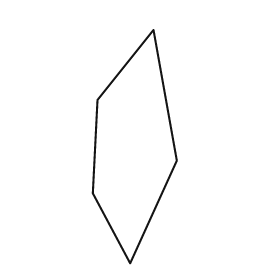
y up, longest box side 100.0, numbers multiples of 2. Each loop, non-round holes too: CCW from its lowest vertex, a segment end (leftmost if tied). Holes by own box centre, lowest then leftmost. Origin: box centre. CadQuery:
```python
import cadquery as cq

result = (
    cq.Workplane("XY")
    .moveTo(-2.0, -50.0)
    .lineTo(18.0, -6.0)
    .lineTo(8.0, 50.0)
    .lineTo(-16.0, 20.0)
    .lineTo(-18.0, -20.0)
    .close()
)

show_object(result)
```